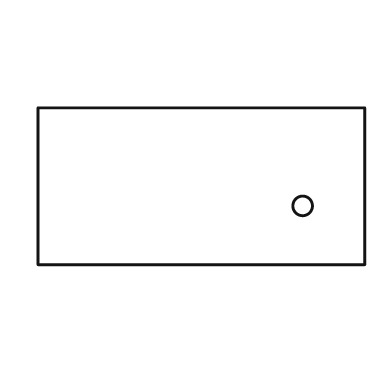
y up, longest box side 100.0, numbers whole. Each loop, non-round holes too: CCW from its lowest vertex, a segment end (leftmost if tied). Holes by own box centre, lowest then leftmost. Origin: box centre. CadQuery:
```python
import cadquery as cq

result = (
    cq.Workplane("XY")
    .moveTo(-50.0, -24.0)
    .lineTo(50.0, -24.0)
    .lineTo(50.0, 24.0)
    .lineTo(-50.0, 24.0)
    .close()
    .moveTo(31.0, -6.0)
    .circle(3.0)
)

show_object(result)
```